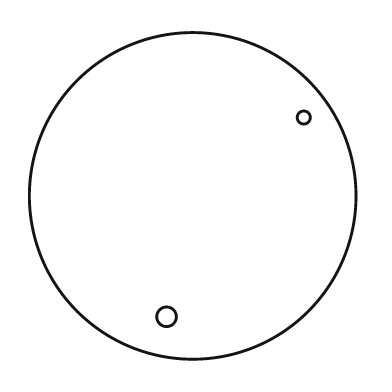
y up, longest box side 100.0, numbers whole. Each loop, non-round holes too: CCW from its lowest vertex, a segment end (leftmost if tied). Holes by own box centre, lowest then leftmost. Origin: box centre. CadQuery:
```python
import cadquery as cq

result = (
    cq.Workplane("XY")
    .moveTo(0.0, 0.0)
    .circle(50.0)
    .moveTo(-8.0, -37.0)
    .circle(3.0)
    .moveTo(34.0, 24.0)
    .circle(2.0)
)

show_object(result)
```